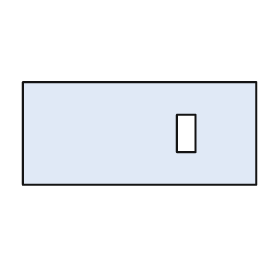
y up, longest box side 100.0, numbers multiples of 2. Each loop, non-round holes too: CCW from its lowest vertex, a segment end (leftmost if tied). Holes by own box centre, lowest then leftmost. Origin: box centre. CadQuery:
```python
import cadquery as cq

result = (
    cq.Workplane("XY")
    .moveTo(-50.0, -22.0)
    .lineTo(50.0, -22.0)
    .lineTo(50.0, 22.0)
    .lineTo(-50.0, 22.0)
    .close()
    .moveTo(16.0, -8.0)
    .lineTo(24.0, -8.0)
    .lineTo(24.0, 8.0)
    .lineTo(16.0, 8.0)
    .close()
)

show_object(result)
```